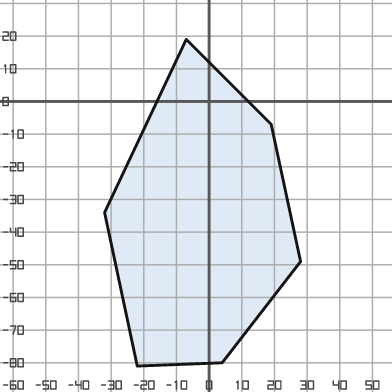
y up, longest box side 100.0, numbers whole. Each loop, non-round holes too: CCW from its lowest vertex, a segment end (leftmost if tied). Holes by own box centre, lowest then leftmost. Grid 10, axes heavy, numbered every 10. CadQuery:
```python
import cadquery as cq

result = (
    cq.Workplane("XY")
    .moveTo(-22.0, -81.0)
    .lineTo(4.0, -80.0)
    .lineTo(28.0, -49.0)
    .lineTo(19.0, -7.0)
    .lineTo(-7.0, 19.0)
    .lineTo(-32.0, -34.0)
    .close()
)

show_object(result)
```